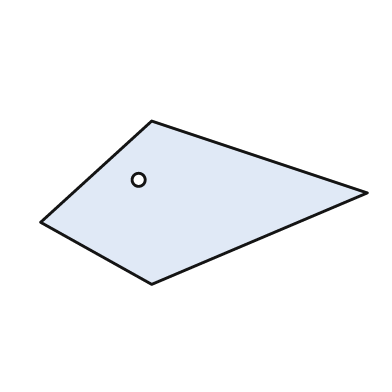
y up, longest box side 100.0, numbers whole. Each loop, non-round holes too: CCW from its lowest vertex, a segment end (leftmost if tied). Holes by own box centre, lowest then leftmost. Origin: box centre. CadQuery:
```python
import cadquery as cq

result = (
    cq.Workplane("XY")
    .moveTo(-16.0, -25.0)
    .lineTo(50.0, 3.0)
    .lineTo(-16.0, 25.0)
    .lineTo(-50.0, -6.0)
    .close()
    .moveTo(-20.0, 7.0)
    .circle(2.0)
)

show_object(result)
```